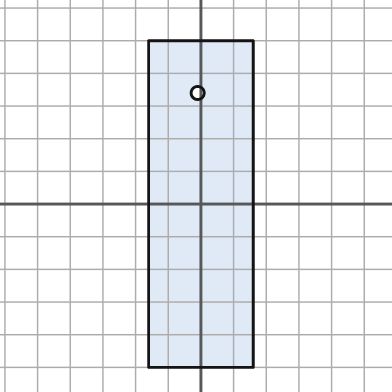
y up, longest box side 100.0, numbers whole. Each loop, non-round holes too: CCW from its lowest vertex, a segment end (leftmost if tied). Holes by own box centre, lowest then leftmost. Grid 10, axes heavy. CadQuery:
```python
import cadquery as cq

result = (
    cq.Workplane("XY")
    .moveTo(-16.0, -50.0)
    .lineTo(16.0, -50.0)
    .lineTo(16.0, 50.0)
    .lineTo(-16.0, 50.0)
    .close()
    .moveTo(-1.0, 34.0)
    .circle(2.0)
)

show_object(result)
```